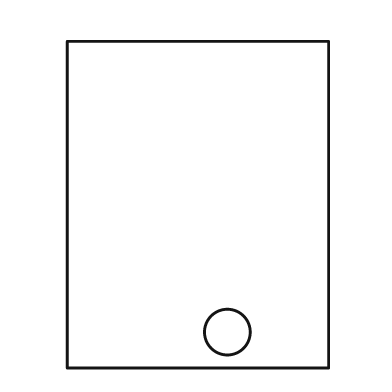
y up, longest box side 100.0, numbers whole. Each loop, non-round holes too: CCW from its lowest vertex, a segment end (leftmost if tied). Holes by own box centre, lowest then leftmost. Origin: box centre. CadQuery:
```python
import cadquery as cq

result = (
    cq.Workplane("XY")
    .moveTo(-40.0, -50.0)
    .lineTo(40.0, -50.0)
    .lineTo(40.0, 50.0)
    .lineTo(-40.0, 50.0)
    .close()
    .moveTo(9.0, -39.0)
    .circle(7.0)
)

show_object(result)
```